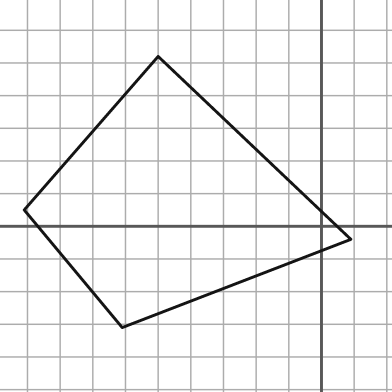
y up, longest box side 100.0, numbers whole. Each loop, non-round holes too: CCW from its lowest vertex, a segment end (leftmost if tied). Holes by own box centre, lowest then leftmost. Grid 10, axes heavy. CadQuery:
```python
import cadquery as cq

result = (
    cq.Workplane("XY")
    .moveTo(-61.0, -31.0)
    .lineTo(9.0, -4.0)
    .lineTo(-50.0, 52.0)
    .lineTo(-91.0, 5.0)
    .close()
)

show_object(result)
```